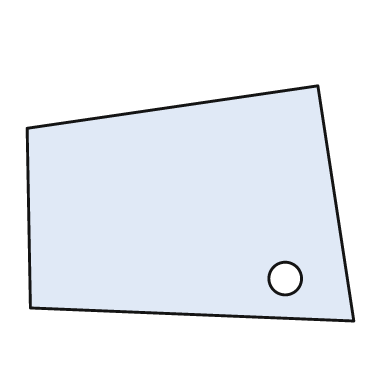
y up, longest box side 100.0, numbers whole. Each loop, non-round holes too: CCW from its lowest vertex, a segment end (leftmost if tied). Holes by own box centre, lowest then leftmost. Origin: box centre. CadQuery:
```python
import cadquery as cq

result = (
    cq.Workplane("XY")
    .moveTo(50.0, -36.0)
    .lineTo(39.0, 36.0)
    .lineTo(-50.0, 23.0)
    .lineTo(-49.0, -32.0)
    .close()
    .moveTo(29.0, -23.0)
    .circle(5.0)
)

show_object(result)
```